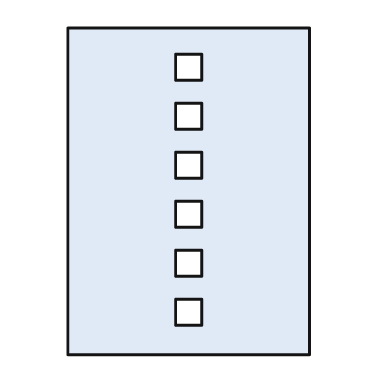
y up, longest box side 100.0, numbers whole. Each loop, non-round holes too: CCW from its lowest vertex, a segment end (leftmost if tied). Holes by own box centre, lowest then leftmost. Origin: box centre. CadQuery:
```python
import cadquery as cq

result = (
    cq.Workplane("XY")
    .moveTo(-37.0, -50.0)
    .lineTo(37.0, -50.0)
    .lineTo(37.0, 50.0)
    .lineTo(-37.0, 50.0)
    .close()
    .moveTo(-4.0, -41.0)
    .lineTo(4.0, -41.0)
    .lineTo(4.0, -33.0)
    .lineTo(-4.0, -33.0)
    .close()
    .moveTo(-4.0, -26.0)
    .lineTo(4.0, -26.0)
    .lineTo(4.0, -18.0)
    .lineTo(-4.0, -18.0)
    .close()
    .moveTo(-4.0, -11.0)
    .lineTo(4.0, -11.0)
    .lineTo(4.0, -3.0)
    .lineTo(-4.0, -3.0)
    .close()
    .moveTo(-4.0, 4.0)
    .lineTo(4.0, 4.0)
    .lineTo(4.0, 12.0)
    .lineTo(-4.0, 12.0)
    .close()
    .moveTo(-4.0, 19.0)
    .lineTo(4.0, 19.0)
    .lineTo(4.0, 27.0)
    .lineTo(-4.0, 27.0)
    .close()
    .moveTo(-4.0, 34.0)
    .lineTo(4.0, 34.0)
    .lineTo(4.0, 42.0)
    .lineTo(-4.0, 42.0)
    .close()
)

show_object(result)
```